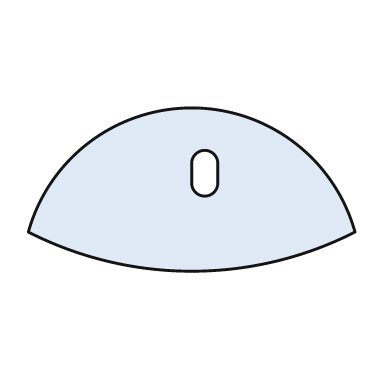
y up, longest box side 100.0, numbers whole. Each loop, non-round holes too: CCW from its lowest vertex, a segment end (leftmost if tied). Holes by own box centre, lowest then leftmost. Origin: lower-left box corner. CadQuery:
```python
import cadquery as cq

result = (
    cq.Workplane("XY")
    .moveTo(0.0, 12.0)
    .threePointArc((50.0, 0.0), (100.0, 12.0))
    .threePointArc((50.0, 50.0), (0.0, 12.0))
    .close()
    .moveTo(50.0, 27.0)
    .threePointArc((54.0, 23.0), (58.0, 27.0))
    .lineTo(58.0, 33.0)
    .threePointArc((54.0, 37.0), (50.0, 33.0))
    .close()
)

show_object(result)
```